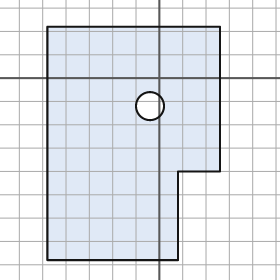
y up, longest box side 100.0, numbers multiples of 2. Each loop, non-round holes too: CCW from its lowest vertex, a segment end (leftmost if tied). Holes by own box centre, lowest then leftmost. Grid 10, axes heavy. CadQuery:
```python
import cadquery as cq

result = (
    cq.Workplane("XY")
    .moveTo(-48.0, -78.0)
    .lineTo(8.0, -78.0)
    .lineTo(8.0, -40.0)
    .lineTo(26.0, -40.0)
    .lineTo(26.0, 22.0)
    .lineTo(-48.0, 22.0)
    .close()
    .moveTo(-4.0, -12.0)
    .circle(6.0)
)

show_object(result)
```